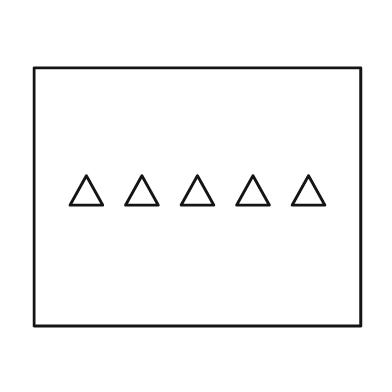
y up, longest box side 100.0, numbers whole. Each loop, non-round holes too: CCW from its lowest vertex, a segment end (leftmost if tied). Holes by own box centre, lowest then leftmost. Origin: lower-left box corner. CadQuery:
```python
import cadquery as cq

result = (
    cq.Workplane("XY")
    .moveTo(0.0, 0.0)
    .lineTo(100.0, 0.0)
    .lineTo(100.0, 79.0)
    .lineTo(0.0, 79.0)
    .close()
    .moveTo(11.0, 37.0)
    .lineTo(21.0, 37.0)
    .lineTo(16.0, 46.0)
    .close()
    .moveTo(28.0, 37.0)
    .lineTo(38.0, 37.0)
    .lineTo(33.0, 46.0)
    .close()
    .moveTo(45.0, 37.0)
    .lineTo(55.0, 37.0)
    .lineTo(50.0, 46.0)
    .close()
    .moveTo(62.0, 37.0)
    .lineTo(72.0, 37.0)
    .lineTo(67.0, 46.0)
    .close()
    .moveTo(79.0, 37.0)
    .lineTo(89.0, 37.0)
    .lineTo(84.0, 46.0)
    .close()
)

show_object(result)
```